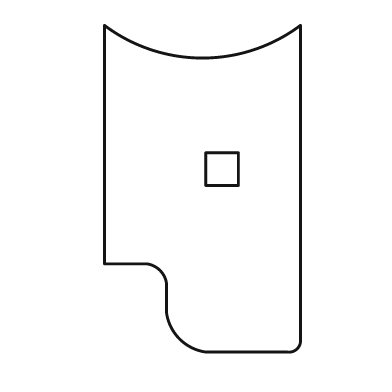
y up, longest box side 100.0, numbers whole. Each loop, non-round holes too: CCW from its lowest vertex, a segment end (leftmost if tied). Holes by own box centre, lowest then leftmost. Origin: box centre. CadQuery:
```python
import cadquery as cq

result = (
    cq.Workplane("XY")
    .moveTo(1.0, -50.0)
    .lineTo(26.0, -50.0)
    .threePointArc((29.0, -49.0), (30.0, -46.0))
    .lineTo(30.0, 50.0)
    .threePointArc((0.0, 40.0), (-30.0, 50.0))
    .lineTo(-30.0, -23.0)
    .lineTo(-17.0, -23.0)
    .threePointArc((-13.0, -25.0), (-11.0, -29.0))
    .lineTo(-11.0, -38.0)
    .threePointArc((-7.0, -46.0), (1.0, -50.0))
    .close()
    .moveTo(1.0, 1.0)
    .lineTo(11.0, 1.0)
    .lineTo(11.0, 11.0)
    .lineTo(1.0, 11.0)
    .close()
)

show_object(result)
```